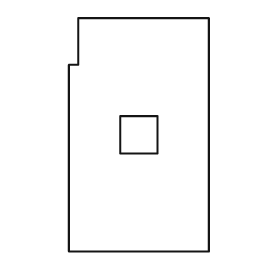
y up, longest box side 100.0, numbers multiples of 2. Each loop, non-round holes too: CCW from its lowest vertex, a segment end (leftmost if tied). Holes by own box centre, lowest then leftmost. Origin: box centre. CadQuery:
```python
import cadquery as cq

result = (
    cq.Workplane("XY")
    .moveTo(-30.0, -50.0)
    .lineTo(30.0, -50.0)
    .lineTo(30.0, 50.0)
    .lineTo(-26.0, 50.0)
    .lineTo(-26.0, 30.0)
    .lineTo(-30.0, 30.0)
    .close()
    .moveTo(-8.0, -8.0)
    .lineTo(8.0, -8.0)
    .lineTo(8.0, 8.0)
    .lineTo(-8.0, 8.0)
    .close()
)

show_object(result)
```